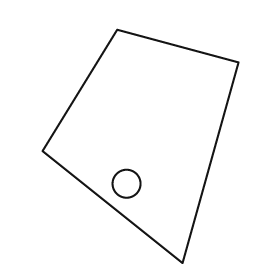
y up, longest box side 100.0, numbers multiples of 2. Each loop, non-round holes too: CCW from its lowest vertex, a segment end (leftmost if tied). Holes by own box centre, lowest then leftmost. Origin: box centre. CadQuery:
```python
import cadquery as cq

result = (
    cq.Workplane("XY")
    .moveTo(18.0, -50.0)
    .lineTo(42.0, 36.0)
    .lineTo(-10.0, 50.0)
    .lineTo(-42.0, -2.0)
    .close()
    .moveTo(-6.0, -16.0)
    .circle(6.0)
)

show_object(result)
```